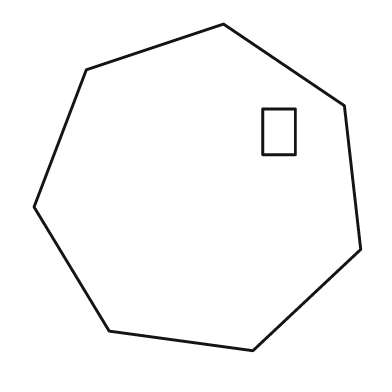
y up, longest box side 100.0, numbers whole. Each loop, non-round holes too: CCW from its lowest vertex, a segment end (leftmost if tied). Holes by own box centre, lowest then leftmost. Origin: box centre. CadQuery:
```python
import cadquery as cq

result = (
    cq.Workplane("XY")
    .moveTo(17.0, -50.0)
    .lineTo(50.0, -19.0)
    .lineTo(45.0, 25.0)
    .lineTo(8.0, 50.0)
    .lineTo(-34.0, 36.0)
    .lineTo(-50.0, -6.0)
    .lineTo(-27.0, -44.0)
    .close()
    .moveTo(20.0, 10.0)
    .lineTo(30.0, 10.0)
    .lineTo(30.0, 24.0)
    .lineTo(20.0, 24.0)
    .close()
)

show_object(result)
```